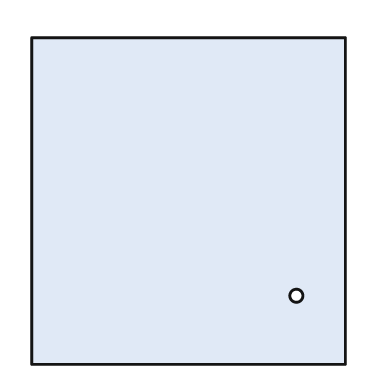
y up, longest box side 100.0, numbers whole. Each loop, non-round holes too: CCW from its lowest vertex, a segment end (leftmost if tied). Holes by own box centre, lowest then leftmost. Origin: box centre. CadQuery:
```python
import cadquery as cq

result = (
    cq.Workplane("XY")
    .moveTo(-48.0, -50.0)
    .lineTo(48.0, -50.0)
    .lineTo(48.0, 50.0)
    .lineTo(-48.0, 50.0)
    .close()
    .moveTo(33.0, -29.0)
    .circle(2.0)
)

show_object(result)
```